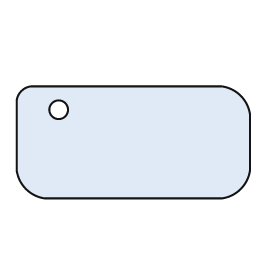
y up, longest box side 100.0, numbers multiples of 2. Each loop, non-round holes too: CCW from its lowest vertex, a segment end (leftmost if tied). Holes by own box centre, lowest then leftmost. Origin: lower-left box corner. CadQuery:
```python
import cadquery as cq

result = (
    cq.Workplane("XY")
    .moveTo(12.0, 0.0)
    .lineTo(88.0, 0.0)
    .threePointArc((96.0, 4.0), (100.0, 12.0))
    .lineTo(100.0, 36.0)
    .threePointArc((96.0, 44.0), (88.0, 48.0))
    .lineTo(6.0, 48.0)
    .threePointArc((2.0, 46.0), (0.0, 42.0))
    .lineTo(0.0, 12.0)
    .threePointArc((4.0, 4.0), (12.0, 0.0))
    .close()
    .moveTo(18.0, 38.0)
    .circle(4.0)
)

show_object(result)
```